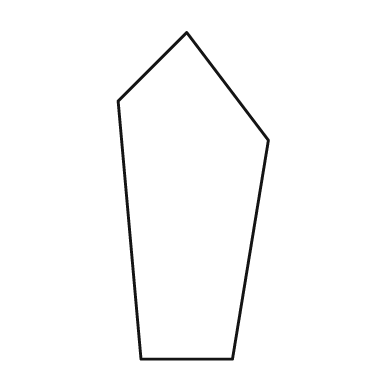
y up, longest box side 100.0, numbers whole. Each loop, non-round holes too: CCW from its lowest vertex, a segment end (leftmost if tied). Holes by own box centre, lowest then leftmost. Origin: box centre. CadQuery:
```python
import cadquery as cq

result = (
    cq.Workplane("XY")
    .moveTo(-16.0, -50.0)
    .lineTo(12.0, -50.0)
    .lineTo(23.0, 17.0)
    .lineTo(-2.0, 50.0)
    .lineTo(-23.0, 29.0)
    .close()
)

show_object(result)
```